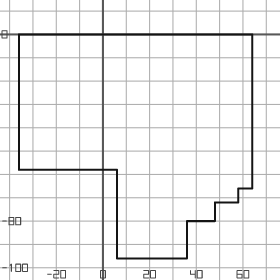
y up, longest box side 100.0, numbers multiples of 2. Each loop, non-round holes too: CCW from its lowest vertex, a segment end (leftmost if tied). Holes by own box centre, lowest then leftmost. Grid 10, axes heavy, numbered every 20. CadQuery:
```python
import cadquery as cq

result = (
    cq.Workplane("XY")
    .moveTo(6.0, -96.0)
    .lineTo(36.0, -96.0)
    .lineTo(36.0, -80.0)
    .lineTo(48.0, -80.0)
    .lineTo(48.0, -72.0)
    .lineTo(58.0, -72.0)
    .lineTo(58.0, -66.0)
    .lineTo(64.0, -66.0)
    .lineTo(64.0, 0.0)
    .lineTo(-36.0, 0.0)
    .lineTo(-36.0, -58.0)
    .lineTo(6.0, -58.0)
    .close()
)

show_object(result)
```